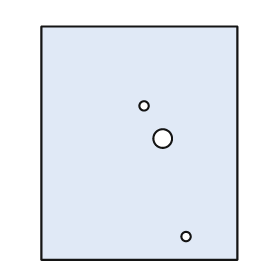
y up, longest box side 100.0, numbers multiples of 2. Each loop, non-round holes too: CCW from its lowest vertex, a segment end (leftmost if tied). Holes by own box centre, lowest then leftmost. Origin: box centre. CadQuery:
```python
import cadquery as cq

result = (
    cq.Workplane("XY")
    .moveTo(-42.0, -50.0)
    .lineTo(42.0, -50.0)
    .lineTo(42.0, 50.0)
    .lineTo(-42.0, 50.0)
    .close()
    .moveTo(20.0, -40.0)
    .circle(2.0)
    .moveTo(10.0, 2.0)
    .circle(4.0)
    .moveTo(2.0, 16.0)
    .circle(2.0)
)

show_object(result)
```